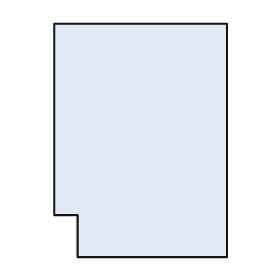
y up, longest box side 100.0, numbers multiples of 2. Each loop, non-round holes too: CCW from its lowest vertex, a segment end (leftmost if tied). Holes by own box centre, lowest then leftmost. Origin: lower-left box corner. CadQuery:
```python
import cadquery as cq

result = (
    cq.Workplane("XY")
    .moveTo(10.0, 0.0)
    .lineTo(74.0, 0.0)
    .lineTo(74.0, 100.0)
    .lineTo(0.0, 100.0)
    .lineTo(0.0, 18.0)
    .lineTo(10.0, 18.0)
    .close()
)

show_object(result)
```